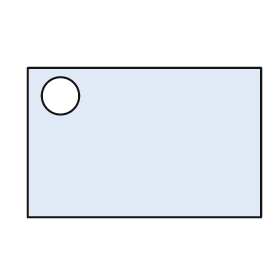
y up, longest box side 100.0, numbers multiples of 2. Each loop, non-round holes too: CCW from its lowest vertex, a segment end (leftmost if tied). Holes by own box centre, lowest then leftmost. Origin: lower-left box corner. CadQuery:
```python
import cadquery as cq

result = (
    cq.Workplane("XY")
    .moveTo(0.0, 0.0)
    .lineTo(100.0, 0.0)
    .lineTo(100.0, 64.0)
    .lineTo(0.0, 64.0)
    .close()
    .moveTo(14.0, 52.0)
    .circle(8.0)
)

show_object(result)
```